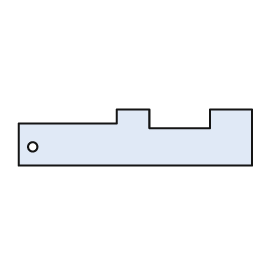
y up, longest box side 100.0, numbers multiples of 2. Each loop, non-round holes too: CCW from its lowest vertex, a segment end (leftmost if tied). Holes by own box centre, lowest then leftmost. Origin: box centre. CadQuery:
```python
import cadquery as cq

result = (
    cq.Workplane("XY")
    .moveTo(-50.0, -12.0)
    .lineTo(50.0, -12.0)
    .lineTo(50.0, 12.0)
    .lineTo(32.0, 12.0)
    .lineTo(32.0, 4.0)
    .lineTo(6.0, 4.0)
    .lineTo(6.0, 12.0)
    .lineTo(-8.0, 12.0)
    .lineTo(-8.0, 6.0)
    .lineTo(-50.0, 6.0)
    .close()
    .moveTo(-44.0, -4.0)
    .circle(2.0)
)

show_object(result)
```